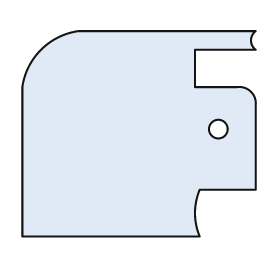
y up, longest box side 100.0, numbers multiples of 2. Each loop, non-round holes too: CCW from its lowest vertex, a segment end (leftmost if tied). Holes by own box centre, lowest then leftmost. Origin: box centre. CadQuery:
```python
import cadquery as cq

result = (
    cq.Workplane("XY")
    .moveTo(-50.0, -44.0)
    .lineTo(26.0, -44.0)
    .threePointArc((24.0, -34.0), (26.0, -24.0))
    .lineTo(50.0, -24.0)
    .lineTo(50.0, 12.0)
    .threePointArc((48.0, 18.0), (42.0, 20.0))
    .lineTo(24.0, 20.0)
    .lineTo(24.0, 36.0)
    .lineTo(50.0, 36.0)
    .threePointArc((48.0, 40.0), (50.0, 44.0))
    .lineTo(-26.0, 44.0)
    .threePointArc((-42.0, 36.0), (-50.0, 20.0))
    .close()
    .moveTo(34.0, 2.0)
    .circle(4.0)
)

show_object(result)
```